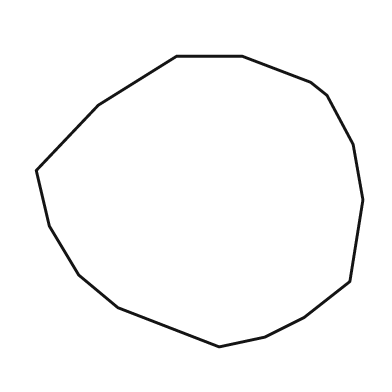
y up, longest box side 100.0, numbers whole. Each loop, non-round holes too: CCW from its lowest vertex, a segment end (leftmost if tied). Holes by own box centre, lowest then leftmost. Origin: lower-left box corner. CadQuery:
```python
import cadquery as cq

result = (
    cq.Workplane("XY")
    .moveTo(56.0, 0.0)
    .lineTo(70.0, 3.0)
    .lineTo(82.0, 9.0)
    .lineTo(96.0, 20.0)
    .lineTo(100.0, 45.0)
    .lineTo(97.0, 62.0)
    .lineTo(89.0, 77.0)
    .lineTo(84.0, 81.0)
    .lineTo(63.0, 89.0)
    .lineTo(43.0, 89.0)
    .lineTo(19.0, 74.0)
    .lineTo(0.0, 54.0)
    .lineTo(4.0, 37.0)
    .lineTo(13.0, 22.0)
    .lineTo(25.0, 12.0)
    .close()
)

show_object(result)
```